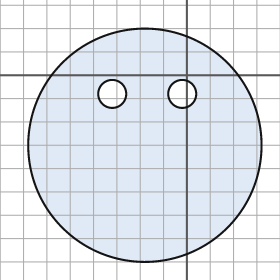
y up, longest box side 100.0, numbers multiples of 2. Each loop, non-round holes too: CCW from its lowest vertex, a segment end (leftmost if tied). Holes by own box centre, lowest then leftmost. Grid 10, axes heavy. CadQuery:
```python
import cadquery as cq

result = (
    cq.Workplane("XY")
    .moveTo(-18.0, -30.0)
    .circle(50.0)
    .moveTo(-32.0, -8.0)
    .circle(6.0)
    .moveTo(-2.0, -8.0)
    .circle(6.0)
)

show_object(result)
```